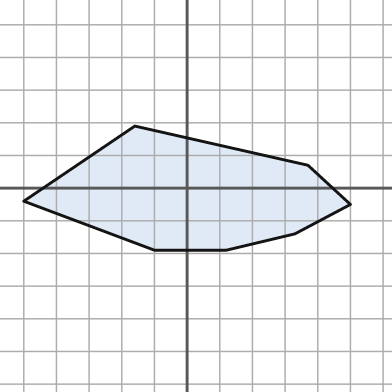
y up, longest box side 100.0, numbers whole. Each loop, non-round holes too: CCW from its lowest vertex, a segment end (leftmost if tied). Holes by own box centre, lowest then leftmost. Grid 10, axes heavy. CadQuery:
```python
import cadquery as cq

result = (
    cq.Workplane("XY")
    .moveTo(-10.0, -19.0)
    .lineTo(12.0, -19.0)
    .lineTo(33.0, -14.0)
    .lineTo(50.0, -5.0)
    .lineTo(37.0, 7.0)
    .lineTo(-16.0, 19.0)
    .lineTo(-50.0, -4.0)
    .close()
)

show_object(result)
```